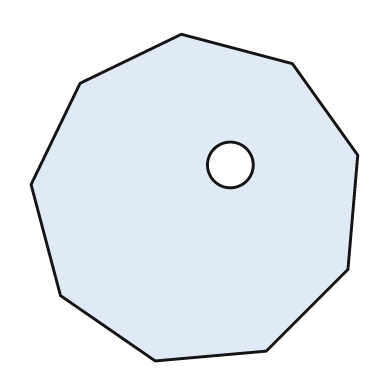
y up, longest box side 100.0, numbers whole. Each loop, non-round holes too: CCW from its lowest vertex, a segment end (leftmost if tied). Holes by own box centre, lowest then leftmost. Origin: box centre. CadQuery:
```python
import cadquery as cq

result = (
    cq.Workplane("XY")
    .moveTo(-12.0, -50.0)
    .lineTo(22.0, -47.0)
    .lineTo(47.0, -22.0)
    .lineTo(50.0, 13.0)
    .lineTo(30.0, 41.0)
    .lineTo(-4.0, 50.0)
    .lineTo(-35.0, 35.0)
    .lineTo(-50.0, 4.0)
    .lineTo(-41.0, -30.0)
    .close()
    .moveTo(11.0, 10.0)
    .circle(7.0)
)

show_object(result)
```